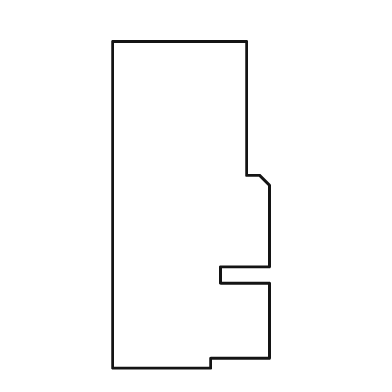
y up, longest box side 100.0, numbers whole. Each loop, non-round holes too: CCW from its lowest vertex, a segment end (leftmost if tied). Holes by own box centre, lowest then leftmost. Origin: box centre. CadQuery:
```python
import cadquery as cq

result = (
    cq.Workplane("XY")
    .moveTo(-24.0, -50.0)
    .lineTo(6.0, -50.0)
    .lineTo(6.0, -47.0)
    .lineTo(24.0, -47.0)
    .lineTo(24.0, -24.0)
    .lineTo(9.0, -24.0)
    .lineTo(9.0, -19.0)
    .lineTo(24.0, -19.0)
    .lineTo(24.0, 6.0)
    .lineTo(21.0, 9.0)
    .lineTo(17.0, 9.0)
    .lineTo(17.0, 50.0)
    .lineTo(-24.0, 50.0)
    .close()
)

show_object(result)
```